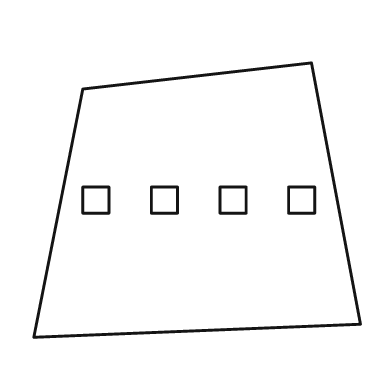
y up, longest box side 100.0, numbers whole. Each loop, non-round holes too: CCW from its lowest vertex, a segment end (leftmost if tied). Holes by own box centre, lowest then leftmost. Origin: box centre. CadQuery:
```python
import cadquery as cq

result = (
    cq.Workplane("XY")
    .moveTo(-50.0, -42.0)
    .lineTo(50.0, -38.0)
    .lineTo(35.0, 42.0)
    .lineTo(-35.0, 34.0)
    .close()
    .moveTo(-35.0, -4.0)
    .lineTo(-27.0, -4.0)
    .lineTo(-27.0, 4.0)
    .lineTo(-35.0, 4.0)
    .close()
    .moveTo(-14.0, -4.0)
    .lineTo(-6.0, -4.0)
    .lineTo(-6.0, 4.0)
    .lineTo(-14.0, 4.0)
    .close()
    .moveTo(7.0, -4.0)
    .lineTo(15.0, -4.0)
    .lineTo(15.0, 4.0)
    .lineTo(7.0, 4.0)
    .close()
    .moveTo(28.0, -4.0)
    .lineTo(36.0, -4.0)
    .lineTo(36.0, 4.0)
    .lineTo(28.0, 4.0)
    .close()
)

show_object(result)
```